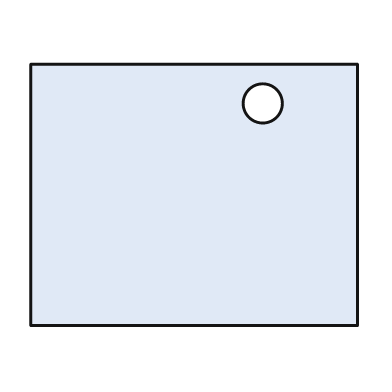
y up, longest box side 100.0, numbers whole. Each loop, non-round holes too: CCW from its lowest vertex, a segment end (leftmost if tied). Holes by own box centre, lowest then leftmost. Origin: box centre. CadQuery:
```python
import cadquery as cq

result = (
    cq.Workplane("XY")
    .moveTo(-50.0, -40.0)
    .lineTo(50.0, -40.0)
    .lineTo(50.0, 40.0)
    .lineTo(-50.0, 40.0)
    .close()
    .moveTo(21.0, 28.0)
    .circle(6.0)
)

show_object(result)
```